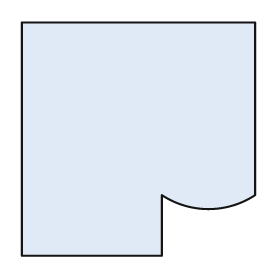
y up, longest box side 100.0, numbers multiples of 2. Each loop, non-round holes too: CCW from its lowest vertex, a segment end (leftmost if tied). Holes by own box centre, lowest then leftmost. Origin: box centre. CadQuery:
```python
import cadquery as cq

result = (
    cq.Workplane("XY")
    .moveTo(-50.0, -50.0)
    .lineTo(10.0, -50.0)
    .lineTo(10.0, -24.0)
    .threePointArc((30.0, -30.0), (50.0, -24.0))
    .lineTo(50.0, 50.0)
    .lineTo(-50.0, 50.0)
    .close()
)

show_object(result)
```